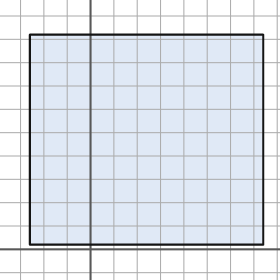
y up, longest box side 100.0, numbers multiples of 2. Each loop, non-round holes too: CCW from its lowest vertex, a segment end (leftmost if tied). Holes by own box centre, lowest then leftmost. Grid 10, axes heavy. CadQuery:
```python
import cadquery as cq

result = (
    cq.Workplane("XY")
    .moveTo(-26.0, 2.0)
    .lineTo(74.0, 2.0)
    .lineTo(74.0, 92.0)
    .lineTo(-26.0, 92.0)
    .close()
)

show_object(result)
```